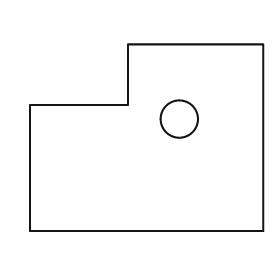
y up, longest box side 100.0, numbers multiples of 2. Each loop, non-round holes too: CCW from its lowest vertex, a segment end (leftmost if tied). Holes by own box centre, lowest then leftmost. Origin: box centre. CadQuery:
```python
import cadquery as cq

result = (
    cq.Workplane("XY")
    .moveTo(-50.0, -40.0)
    .lineTo(50.0, -40.0)
    .lineTo(50.0, 40.0)
    .lineTo(-8.0, 40.0)
    .lineTo(-8.0, 14.0)
    .lineTo(-50.0, 14.0)
    .close()
    .moveTo(14.0, 8.0)
    .circle(8.0)
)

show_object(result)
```